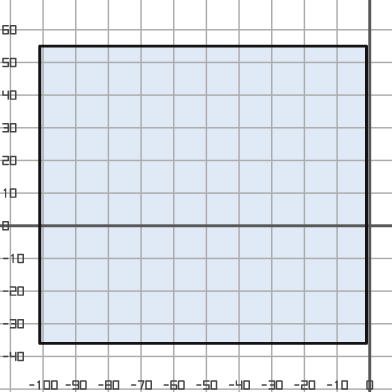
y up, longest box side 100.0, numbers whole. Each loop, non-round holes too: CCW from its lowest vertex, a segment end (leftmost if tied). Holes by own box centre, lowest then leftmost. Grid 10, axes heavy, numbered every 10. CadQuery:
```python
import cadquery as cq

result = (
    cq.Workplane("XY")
    .moveTo(-101.0, -36.0)
    .lineTo(-1.0, -36.0)
    .lineTo(-1.0, 55.0)
    .lineTo(-101.0, 55.0)
    .close()
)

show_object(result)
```